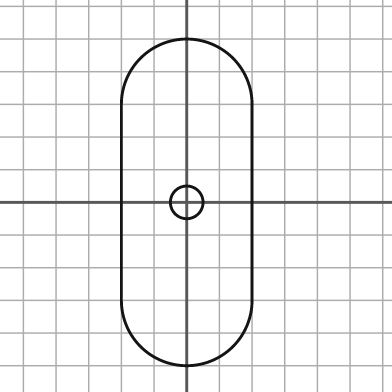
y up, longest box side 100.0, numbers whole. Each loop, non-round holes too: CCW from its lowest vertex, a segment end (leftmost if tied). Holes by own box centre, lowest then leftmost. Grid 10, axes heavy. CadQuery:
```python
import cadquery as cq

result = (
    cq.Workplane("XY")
    .moveTo(-20.0, -30.0)
    .threePointArc((0.0, -50.0), (20.0, -30.0))
    .lineTo(20.0, 30.0)
    .threePointArc((0.0, 50.0), (-20.0, 30.0))
    .close()
    .moveTo(0.0, 0.0)
    .circle(5.0)
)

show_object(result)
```